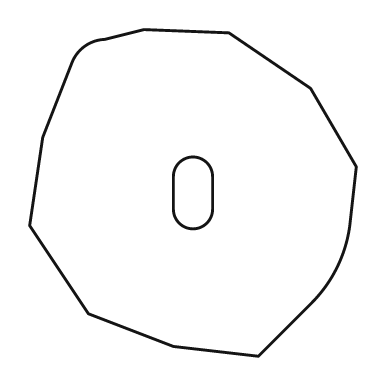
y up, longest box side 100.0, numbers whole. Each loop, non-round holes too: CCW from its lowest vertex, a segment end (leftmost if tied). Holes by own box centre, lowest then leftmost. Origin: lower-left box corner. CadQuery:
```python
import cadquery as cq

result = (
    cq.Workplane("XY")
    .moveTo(70.0, 0.0)
    .lineTo(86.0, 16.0)
    .threePointArc((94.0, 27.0), (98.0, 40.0))
    .lineTo(100.0, 58.0)
    .lineTo(86.0, 82.0)
    .lineTo(61.0, 99.0)
    .lineTo(35.0, 100.0)
    .lineTo(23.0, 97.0)
    .threePointArc((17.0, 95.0), (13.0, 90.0))
    .lineTo(4.0, 67.0)
    .lineTo(0.0, 40.0)
    .lineTo(18.0, 13.0)
    .lineTo(44.0, 3.0)
    .close()
    .moveTo(44.0, 45.0)
    .threePointArc((50.0, 39.0), (56.0, 45.0))
    .lineTo(56.0, 55.0)
    .threePointArc((50.0, 61.0), (44.0, 55.0))
    .close()
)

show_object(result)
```